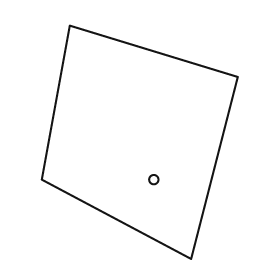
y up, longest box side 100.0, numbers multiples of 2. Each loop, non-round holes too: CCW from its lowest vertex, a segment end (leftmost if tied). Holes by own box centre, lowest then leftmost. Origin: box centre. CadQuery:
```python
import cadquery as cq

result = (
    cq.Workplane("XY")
    .moveTo(22.0, -50.0)
    .lineTo(42.0, 28.0)
    .lineTo(-30.0, 50.0)
    .lineTo(-42.0, -16.0)
    .close()
    .moveTo(6.0, -16.0)
    .circle(2.0)
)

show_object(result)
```